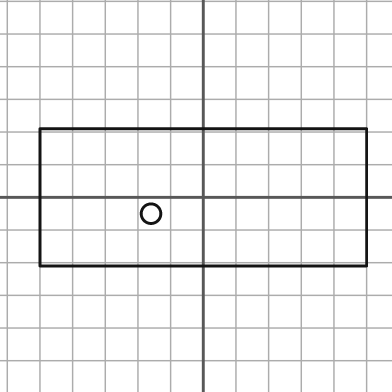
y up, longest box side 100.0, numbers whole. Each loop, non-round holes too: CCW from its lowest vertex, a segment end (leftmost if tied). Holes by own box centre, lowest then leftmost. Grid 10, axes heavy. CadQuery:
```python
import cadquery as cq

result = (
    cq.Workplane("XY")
    .moveTo(-50.0, -21.0)
    .lineTo(50.0, -21.0)
    .lineTo(50.0, 21.0)
    .lineTo(-50.0, 21.0)
    .close()
    .moveTo(-16.0, -5.0)
    .circle(3.0)
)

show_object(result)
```